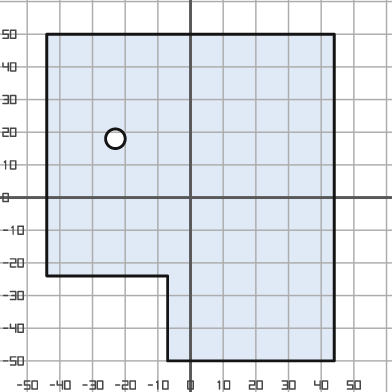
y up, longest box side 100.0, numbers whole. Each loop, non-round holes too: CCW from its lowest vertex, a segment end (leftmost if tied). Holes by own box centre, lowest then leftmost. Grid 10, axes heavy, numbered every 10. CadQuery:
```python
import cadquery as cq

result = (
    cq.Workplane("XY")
    .moveTo(-7.0, -50.0)
    .lineTo(44.0, -50.0)
    .lineTo(44.0, 50.0)
    .lineTo(-44.0, 50.0)
    .lineTo(-44.0, -24.0)
    .lineTo(-7.0, -24.0)
    .close()
    .moveTo(-23.0, 18.0)
    .circle(3.0)
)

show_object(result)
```